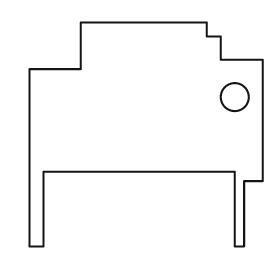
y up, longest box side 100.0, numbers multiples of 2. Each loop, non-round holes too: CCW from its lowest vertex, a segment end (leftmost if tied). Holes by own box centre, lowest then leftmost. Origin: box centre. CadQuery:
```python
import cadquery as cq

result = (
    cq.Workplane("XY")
    .moveTo(-50.0, -48.0)
    .lineTo(-44.0, -48.0)
    .lineTo(-44.0, -16.0)
    .lineTo(38.0, -16.0)
    .lineTo(38.0, -48.0)
    .lineTo(42.0, -48.0)
    .lineTo(42.0, -20.0)
    .lineTo(50.0, -20.0)
    .lineTo(50.0, 32.0)
    .lineTo(32.0, 32.0)
    .lineTo(32.0, 42.0)
    .lineTo(26.0, 42.0)
    .lineTo(26.0, 48.0)
    .lineTo(-28.0, 48.0)
    .lineTo(-28.0, 28.0)
    .lineTo(-50.0, 28.0)
    .close()
    .moveTo(38.0, 16.0)
    .circle(6.0)
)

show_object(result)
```